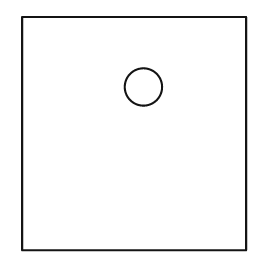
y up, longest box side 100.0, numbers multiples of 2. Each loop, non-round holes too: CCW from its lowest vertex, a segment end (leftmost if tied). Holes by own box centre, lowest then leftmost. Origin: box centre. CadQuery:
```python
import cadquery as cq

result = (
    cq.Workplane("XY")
    .moveTo(-48.0, -50.0)
    .lineTo(48.0, -50.0)
    .lineTo(48.0, 50.0)
    .lineTo(-48.0, 50.0)
    .close()
    .moveTo(4.0, 20.0)
    .circle(8.0)
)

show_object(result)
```